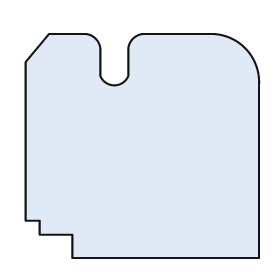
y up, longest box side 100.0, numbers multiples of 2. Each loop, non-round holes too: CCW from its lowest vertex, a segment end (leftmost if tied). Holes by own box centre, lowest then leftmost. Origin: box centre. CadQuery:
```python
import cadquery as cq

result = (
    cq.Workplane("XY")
    .moveTo(-30.0, -48.0)
    .lineTo(50.0, -48.0)
    .lineTo(50.0, 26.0)
    .threePointArc((44.0, 42.0), (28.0, 48.0))
    .lineTo(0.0, 48.0)
    .threePointArc((-4.0, 46.0), (-6.0, 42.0))
    .lineTo(-6.0, 30.0)
    .threePointArc((-12.0, 26.0), (-18.0, 30.0))
    .lineTo(-18.0, 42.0)
    .threePointArc((-20.0, 46.0), (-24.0, 48.0))
    .lineTo(-40.0, 48.0)
    .lineTo(-50.0, 36.0)
    .lineTo(-50.0, -32.0)
    .lineTo(-44.0, -32.0)
    .lineTo(-44.0, -38.0)
    .lineTo(-30.0, -38.0)
    .close()
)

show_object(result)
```